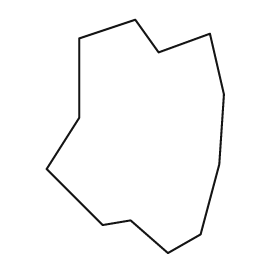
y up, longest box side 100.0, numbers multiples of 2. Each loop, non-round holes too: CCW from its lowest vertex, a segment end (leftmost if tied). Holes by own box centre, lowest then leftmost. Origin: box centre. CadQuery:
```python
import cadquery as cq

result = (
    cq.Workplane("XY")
    .moveTo(14.0, -50.0)
    .lineTo(28.0, -42.0)
    .lineTo(36.0, -12.0)
    .lineTo(38.0, 18.0)
    .lineTo(32.0, 44.0)
    .lineTo(10.0, 36.0)
    .lineTo(0.0, 50.0)
    .lineTo(-24.0, 42.0)
    .lineTo(-24.0, 8.0)
    .lineTo(-38.0, -14.0)
    .lineTo(-14.0, -38.0)
    .lineTo(-2.0, -36.0)
    .close()
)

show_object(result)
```